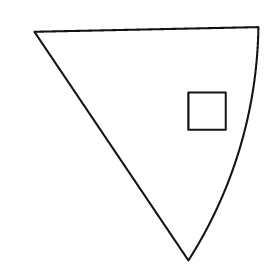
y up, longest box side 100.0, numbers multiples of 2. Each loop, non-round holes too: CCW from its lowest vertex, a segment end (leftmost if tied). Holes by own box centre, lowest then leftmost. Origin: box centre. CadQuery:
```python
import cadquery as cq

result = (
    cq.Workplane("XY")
    .moveTo(18.0, -50.0)
    .threePointArc((40.0, -2.0), (48.0, 50.0))
    .lineTo(-48.0, 48.0)
    .close()
    .moveTo(18.0, 6.0)
    .lineTo(34.0, 6.0)
    .lineTo(34.0, 22.0)
    .lineTo(18.0, 22.0)
    .close()
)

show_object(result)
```